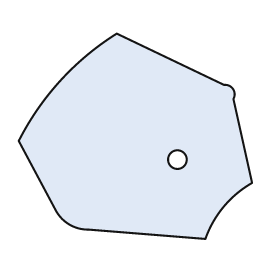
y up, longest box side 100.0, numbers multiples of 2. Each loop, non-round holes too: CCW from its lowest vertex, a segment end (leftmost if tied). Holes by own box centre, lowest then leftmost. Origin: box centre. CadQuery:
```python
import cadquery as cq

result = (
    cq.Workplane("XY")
    .moveTo(30.0, -44.0)
    .threePointArc((38.0, -30.0), (50.0, -20.0))
    .lineTo(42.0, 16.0)
    .threePointArc((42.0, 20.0), (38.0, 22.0))
    .lineTo(-8.0, 44.0)
    .threePointArc((-32.0, 24.0), (-50.0, -2.0))
    .lineTo(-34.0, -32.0)
    .threePointArc((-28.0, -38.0), (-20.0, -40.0))
    .close()
    .moveTo(18.0, -10.0)
    .circle(4.0)
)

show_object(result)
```